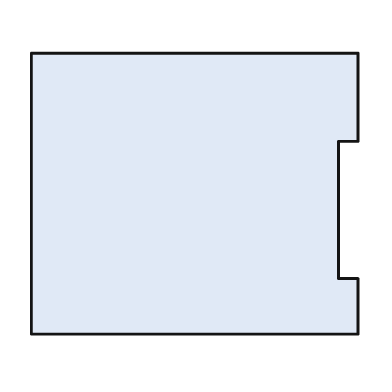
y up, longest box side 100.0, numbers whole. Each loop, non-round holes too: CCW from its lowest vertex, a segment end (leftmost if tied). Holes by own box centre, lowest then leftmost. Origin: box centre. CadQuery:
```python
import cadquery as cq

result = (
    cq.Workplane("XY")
    .moveTo(-50.0, -43.0)
    .lineTo(50.0, -43.0)
    .lineTo(50.0, -26.0)
    .lineTo(44.0, -26.0)
    .lineTo(44.0, 16.0)
    .lineTo(50.0, 16.0)
    .lineTo(50.0, 43.0)
    .lineTo(-50.0, 43.0)
    .close()
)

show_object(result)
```